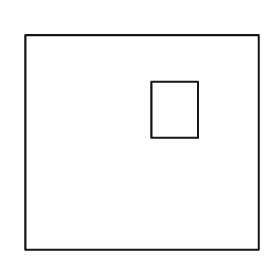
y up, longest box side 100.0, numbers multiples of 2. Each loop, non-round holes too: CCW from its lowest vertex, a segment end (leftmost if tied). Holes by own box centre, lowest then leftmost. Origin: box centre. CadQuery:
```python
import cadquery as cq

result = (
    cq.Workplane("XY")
    .moveTo(-50.0, -46.0)
    .lineTo(50.0, -46.0)
    .lineTo(50.0, 46.0)
    .lineTo(-50.0, 46.0)
    .close()
    .moveTo(4.0, 2.0)
    .lineTo(24.0, 2.0)
    .lineTo(24.0, 26.0)
    .lineTo(4.0, 26.0)
    .close()
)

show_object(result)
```